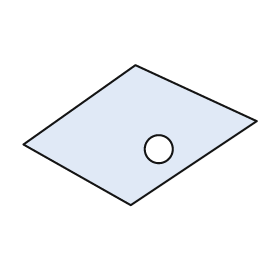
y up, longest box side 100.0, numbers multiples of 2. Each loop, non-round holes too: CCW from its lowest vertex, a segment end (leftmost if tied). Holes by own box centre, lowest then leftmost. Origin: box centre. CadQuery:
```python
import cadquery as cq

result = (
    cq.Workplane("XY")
    .moveTo(-4.0, -30.0)
    .lineTo(50.0, 6.0)
    .lineTo(-2.0, 30.0)
    .lineTo(-50.0, -4.0)
    .close()
    .moveTo(8.0, -6.0)
    .circle(6.0)
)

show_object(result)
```